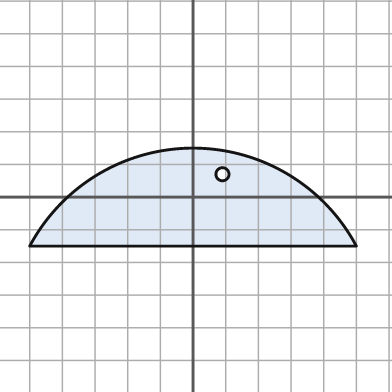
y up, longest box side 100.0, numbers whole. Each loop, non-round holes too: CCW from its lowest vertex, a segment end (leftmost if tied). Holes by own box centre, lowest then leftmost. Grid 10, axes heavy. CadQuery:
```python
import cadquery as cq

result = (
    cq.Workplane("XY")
    .moveTo(-50.0, -15.0)
    .lineTo(50.0, -15.0)
    .threePointArc((0.0, 15.0), (-50.0, -15.0))
    .close()
    .moveTo(9.0, 7.0)
    .circle(2.0)
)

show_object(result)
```